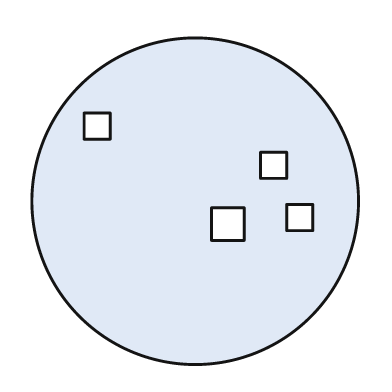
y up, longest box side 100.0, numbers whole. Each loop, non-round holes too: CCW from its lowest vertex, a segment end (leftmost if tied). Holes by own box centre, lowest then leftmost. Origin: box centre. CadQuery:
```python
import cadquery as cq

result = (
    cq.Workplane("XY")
    .moveTo(0.0, 0.0)
    .circle(50.0)
    .moveTo(5.0, -12.0)
    .lineTo(15.0, -12.0)
    .lineTo(15.0, -2.0)
    .lineTo(5.0, -2.0)
    .close()
    .moveTo(28.0, -9.0)
    .lineTo(36.0, -9.0)
    .lineTo(36.0, -1.0)
    .lineTo(28.0, -1.0)
    .close()
    .moveTo(20.0, 7.0)
    .lineTo(28.0, 7.0)
    .lineTo(28.0, 15.0)
    .lineTo(20.0, 15.0)
    .close()
    .moveTo(-34.0, 19.0)
    .lineTo(-26.0, 19.0)
    .lineTo(-26.0, 27.0)
    .lineTo(-34.0, 27.0)
    .close()
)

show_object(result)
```